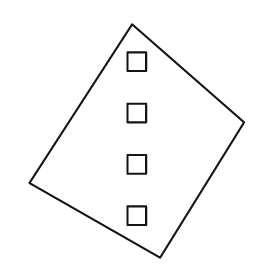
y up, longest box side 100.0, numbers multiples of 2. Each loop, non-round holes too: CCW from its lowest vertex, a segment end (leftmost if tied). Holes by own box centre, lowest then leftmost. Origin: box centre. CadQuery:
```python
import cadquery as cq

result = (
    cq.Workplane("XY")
    .moveTo(10.0, -50.0)
    .lineTo(46.0, 8.0)
    .lineTo(-2.0, 50.0)
    .lineTo(-46.0, -18.0)
    .close()
    .moveTo(-4.0, -36.0)
    .lineTo(4.0, -36.0)
    .lineTo(4.0, -28.0)
    .lineTo(-4.0, -28.0)
    .close()
    .moveTo(-4.0, -14.0)
    .lineTo(4.0, -14.0)
    .lineTo(4.0, -6.0)
    .lineTo(-4.0, -6.0)
    .close()
    .moveTo(-4.0, 8.0)
    .lineTo(4.0, 8.0)
    .lineTo(4.0, 16.0)
    .lineTo(-4.0, 16.0)
    .close()
    .moveTo(-4.0, 30.0)
    .lineTo(4.0, 30.0)
    .lineTo(4.0, 38.0)
    .lineTo(-4.0, 38.0)
    .close()
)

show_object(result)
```